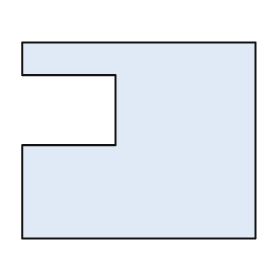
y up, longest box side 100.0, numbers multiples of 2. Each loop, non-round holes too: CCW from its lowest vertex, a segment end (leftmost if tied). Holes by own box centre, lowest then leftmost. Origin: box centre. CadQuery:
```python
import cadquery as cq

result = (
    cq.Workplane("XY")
    .moveTo(-50.0, -42.0)
    .lineTo(50.0, -42.0)
    .lineTo(50.0, 42.0)
    .lineTo(-50.0, 42.0)
    .lineTo(-50.0, 28.0)
    .lineTo(-10.0, 28.0)
    .lineTo(-10.0, -2.0)
    .lineTo(-50.0, -2.0)
    .close()
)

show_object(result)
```